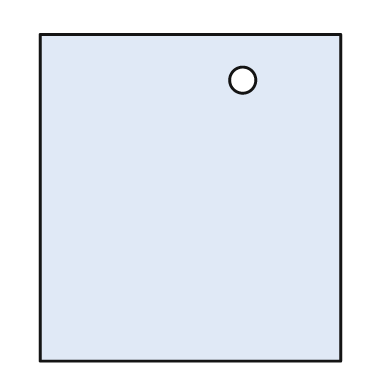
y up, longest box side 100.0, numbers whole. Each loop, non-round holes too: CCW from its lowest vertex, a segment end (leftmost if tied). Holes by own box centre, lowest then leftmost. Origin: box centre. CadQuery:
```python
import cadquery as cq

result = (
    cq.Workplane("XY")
    .moveTo(-46.0, -50.0)
    .lineTo(46.0, -50.0)
    .lineTo(46.0, 50.0)
    .lineTo(-46.0, 50.0)
    .close()
    .moveTo(16.0, 36.0)
    .circle(4.0)
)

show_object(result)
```